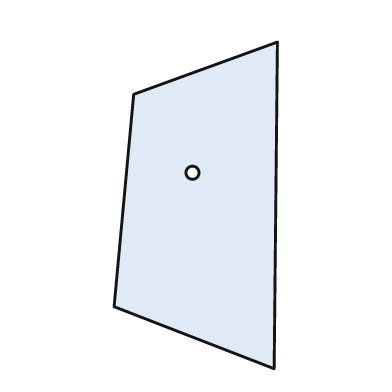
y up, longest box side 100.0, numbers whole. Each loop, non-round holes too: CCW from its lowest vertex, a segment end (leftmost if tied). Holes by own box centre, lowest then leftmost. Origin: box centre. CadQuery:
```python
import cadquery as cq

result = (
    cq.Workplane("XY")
    .moveTo(24.0, -50.0)
    .lineTo(25.0, 50.0)
    .lineTo(-19.0, 34.0)
    .lineTo(-25.0, -31.0)
    .close()
    .moveTo(-1.0, 10.0)
    .circle(2.0)
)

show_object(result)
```